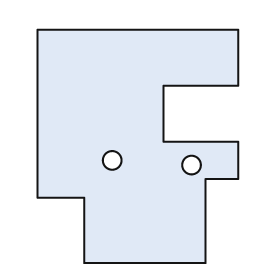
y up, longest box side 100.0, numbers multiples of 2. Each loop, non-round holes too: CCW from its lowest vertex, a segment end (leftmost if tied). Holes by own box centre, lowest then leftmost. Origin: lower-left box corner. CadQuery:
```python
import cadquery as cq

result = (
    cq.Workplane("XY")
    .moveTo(20.0, 0.0)
    .lineTo(72.0, 0.0)
    .lineTo(72.0, 36.0)
    .lineTo(86.0, 36.0)
    .lineTo(86.0, 52.0)
    .lineTo(54.0, 52.0)
    .lineTo(54.0, 76.0)
    .lineTo(86.0, 76.0)
    .lineTo(86.0, 100.0)
    .lineTo(0.0, 100.0)
    .lineTo(0.0, 28.0)
    .lineTo(20.0, 28.0)
    .close()
    .moveTo(66.0, 42.0)
    .circle(4.0)
    .moveTo(32.0, 44.0)
    .circle(4.0)
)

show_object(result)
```